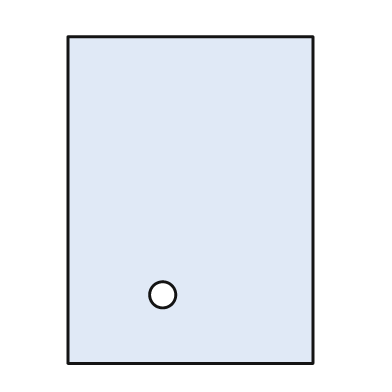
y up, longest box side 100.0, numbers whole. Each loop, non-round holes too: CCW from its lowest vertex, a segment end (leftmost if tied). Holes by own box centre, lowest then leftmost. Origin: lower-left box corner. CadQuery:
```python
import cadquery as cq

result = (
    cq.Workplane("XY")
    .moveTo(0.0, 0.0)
    .lineTo(75.0, 0.0)
    .lineTo(75.0, 100.0)
    .lineTo(0.0, 100.0)
    .close()
    .moveTo(29.0, 21.0)
    .circle(4.0)
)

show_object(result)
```